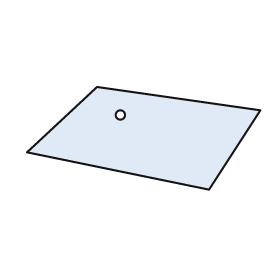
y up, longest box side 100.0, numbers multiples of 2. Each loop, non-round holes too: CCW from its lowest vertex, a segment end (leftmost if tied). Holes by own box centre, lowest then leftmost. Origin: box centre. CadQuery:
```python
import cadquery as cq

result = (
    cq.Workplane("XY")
    .moveTo(28.0, -22.0)
    .lineTo(50.0, 12.0)
    .lineTo(-20.0, 22.0)
    .lineTo(-50.0, -6.0)
    .close()
    .moveTo(-10.0, 10.0)
    .circle(2.0)
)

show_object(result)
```